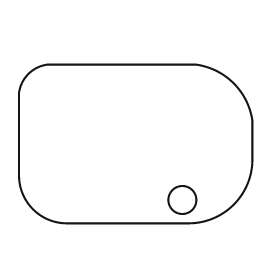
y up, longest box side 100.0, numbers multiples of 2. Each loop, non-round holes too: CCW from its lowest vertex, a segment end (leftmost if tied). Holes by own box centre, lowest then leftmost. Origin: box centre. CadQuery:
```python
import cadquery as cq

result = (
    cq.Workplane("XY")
    .moveTo(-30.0, -34.0)
    .lineTo(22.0, -34.0)
    .threePointArc((42.0, -26.0), (50.0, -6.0))
    .lineTo(50.0, 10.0)
    .threePointArc((42.0, 26.0), (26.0, 34.0))
    .lineTo(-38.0, 34.0)
    .threePointArc((-46.0, 30.0), (-50.0, 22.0))
    .lineTo(-50.0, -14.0)
    .threePointArc((-44.0, -28.0), (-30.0, -34.0))
    .close()
    .moveTo(20.0, -24.0)
    .circle(6.0)
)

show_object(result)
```